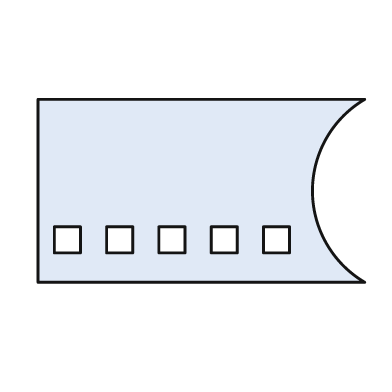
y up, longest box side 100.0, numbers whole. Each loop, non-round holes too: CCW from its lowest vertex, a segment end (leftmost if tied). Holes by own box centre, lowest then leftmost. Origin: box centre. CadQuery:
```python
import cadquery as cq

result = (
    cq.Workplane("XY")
    .moveTo(-50.0, -28.0)
    .lineTo(50.0, -28.0)
    .threePointArc((34.0, 0.0), (50.0, 28.0))
    .lineTo(-50.0, 28.0)
    .close()
    .moveTo(-45.0, -19.0)
    .lineTo(-37.0, -19.0)
    .lineTo(-37.0, -11.0)
    .lineTo(-45.0, -11.0)
    .close()
    .moveTo(-29.0, -19.0)
    .lineTo(-21.0, -19.0)
    .lineTo(-21.0, -11.0)
    .lineTo(-29.0, -11.0)
    .close()
    .moveTo(-13.0, -19.0)
    .lineTo(-5.0, -19.0)
    .lineTo(-5.0, -11.0)
    .lineTo(-13.0, -11.0)
    .close()
    .moveTo(3.0, -19.0)
    .lineTo(11.0, -19.0)
    .lineTo(11.0, -11.0)
    .lineTo(3.0, -11.0)
    .close()
    .moveTo(19.0, -19.0)
    .lineTo(27.0, -19.0)
    .lineTo(27.0, -11.0)
    .lineTo(19.0, -11.0)
    .close()
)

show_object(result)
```